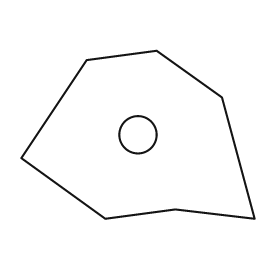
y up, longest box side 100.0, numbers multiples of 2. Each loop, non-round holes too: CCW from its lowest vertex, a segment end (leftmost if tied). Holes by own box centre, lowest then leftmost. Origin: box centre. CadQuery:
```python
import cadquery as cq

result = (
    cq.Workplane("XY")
    .moveTo(-14.0, -36.0)
    .lineTo(16.0, -32.0)
    .lineTo(50.0, -36.0)
    .lineTo(36.0, 16.0)
    .lineTo(8.0, 36.0)
    .lineTo(-22.0, 32.0)
    .lineTo(-50.0, -10.0)
    .close()
    .moveTo(0.0, 0.0)
    .circle(8.0)
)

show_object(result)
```